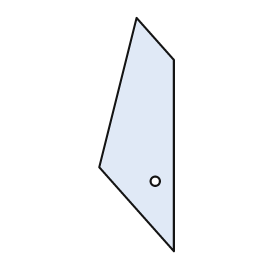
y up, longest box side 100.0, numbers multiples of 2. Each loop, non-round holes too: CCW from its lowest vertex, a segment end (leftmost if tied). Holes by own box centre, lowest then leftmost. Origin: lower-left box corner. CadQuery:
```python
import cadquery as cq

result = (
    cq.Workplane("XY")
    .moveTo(32.0, 0.0)
    .lineTo(32.0, 82.0)
    .lineTo(16.0, 100.0)
    .lineTo(0.0, 36.0)
    .close()
    .moveTo(24.0, 30.0)
    .circle(2.0)
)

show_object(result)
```